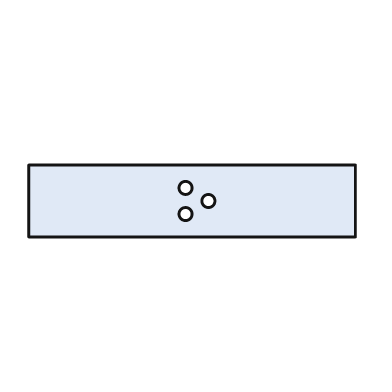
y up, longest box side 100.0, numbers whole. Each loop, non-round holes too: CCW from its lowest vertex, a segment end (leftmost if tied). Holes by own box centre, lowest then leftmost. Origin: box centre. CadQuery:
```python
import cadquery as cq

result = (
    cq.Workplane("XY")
    .moveTo(-50.0, -11.0)
    .lineTo(50.0, -11.0)
    .lineTo(50.0, 11.0)
    .lineTo(-50.0, 11.0)
    .close()
    .moveTo(-2.0, -4.0)
    .circle(2.0)
    .moveTo(5.0, 0.0)
    .circle(2.0)
    .moveTo(-2.0, 4.0)
    .circle(2.0)
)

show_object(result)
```